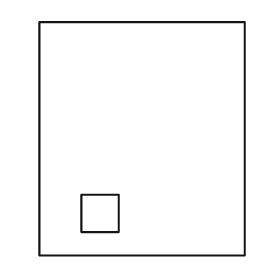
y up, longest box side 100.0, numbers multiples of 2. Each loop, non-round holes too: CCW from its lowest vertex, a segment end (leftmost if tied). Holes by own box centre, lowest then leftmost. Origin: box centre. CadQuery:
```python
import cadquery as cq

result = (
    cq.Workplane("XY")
    .moveTo(-44.0, -50.0)
    .lineTo(44.0, -50.0)
    .lineTo(44.0, 50.0)
    .lineTo(-44.0, 50.0)
    .close()
    .moveTo(-26.0, -40.0)
    .lineTo(-10.0, -40.0)
    .lineTo(-10.0, -24.0)
    .lineTo(-26.0, -24.0)
    .close()
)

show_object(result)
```